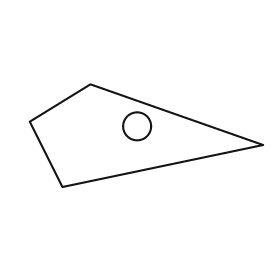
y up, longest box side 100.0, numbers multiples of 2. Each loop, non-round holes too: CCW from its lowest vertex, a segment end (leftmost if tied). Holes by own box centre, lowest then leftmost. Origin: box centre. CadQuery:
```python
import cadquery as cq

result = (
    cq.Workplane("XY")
    .moveTo(-36.0, -22.0)
    .lineTo(50.0, -4.0)
    .lineTo(-24.0, 22.0)
    .lineTo(-50.0, 6.0)
    .close()
    .moveTo(-4.0, 4.0)
    .circle(6.0)
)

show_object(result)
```